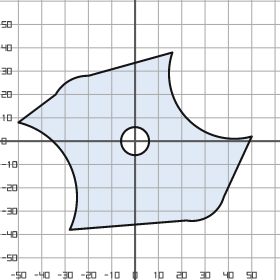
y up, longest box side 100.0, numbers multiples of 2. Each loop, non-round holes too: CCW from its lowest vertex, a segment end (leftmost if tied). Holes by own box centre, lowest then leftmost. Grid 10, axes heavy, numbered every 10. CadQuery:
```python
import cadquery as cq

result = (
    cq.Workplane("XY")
    .moveTo(-28.0, -38.0)
    .lineTo(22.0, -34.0)
    .threePointArc((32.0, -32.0), (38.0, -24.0))
    .lineTo(50.0, 2.0)
    .threePointArc((22.0, 10.0), (16.0, 38.0))
    .lineTo(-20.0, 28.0)
    .threePointArc((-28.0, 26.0), (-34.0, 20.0))
    .lineTo(-50.0, 8.0)
    .threePointArc((-28.0, -10.0), (-28.0, -38.0))
    .close()
    .moveTo(0.0, 0.0)
    .circle(6.0)
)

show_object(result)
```